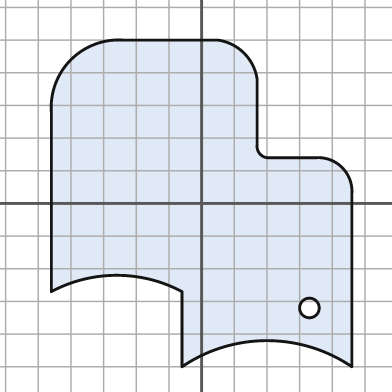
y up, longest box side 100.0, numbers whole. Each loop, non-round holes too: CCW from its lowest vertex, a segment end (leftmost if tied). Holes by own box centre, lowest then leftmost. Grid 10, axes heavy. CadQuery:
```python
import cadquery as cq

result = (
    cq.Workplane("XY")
    .moveTo(-6.0, -50.0)
    .threePointArc((20.0, -42.0), (46.0, -50.0))
    .lineTo(46.0, 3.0)
    .threePointArc((43.0, 11.0), (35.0, 14.0))
    .lineTo(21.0, 14.0)
    .threePointArc((18.0, 15.0), (17.0, 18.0))
    .lineTo(17.0, 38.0)
    .threePointArc((13.0, 46.0), (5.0, 50.0))
    .lineTo(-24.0, 50.0)
    .threePointArc((-40.0, 44.0), (-46.0, 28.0))
    .lineTo(-46.0, -27.0)
    .threePointArc((-26.0, -22.0), (-6.0, -27.0))
    .close()
    .moveTo(33.0, -32.0)
    .circle(3.0)
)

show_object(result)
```